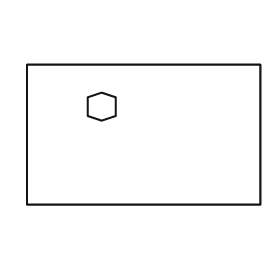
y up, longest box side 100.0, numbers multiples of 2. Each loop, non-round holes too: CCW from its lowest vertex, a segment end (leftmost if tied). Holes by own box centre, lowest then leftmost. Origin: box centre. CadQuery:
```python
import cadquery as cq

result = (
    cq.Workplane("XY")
    .moveTo(-50.0, -30.0)
    .lineTo(50.0, -30.0)
    .lineTo(50.0, 30.0)
    .lineTo(-50.0, 30.0)
    .close()
    .moveTo(-18.0, 6.0)
    .lineTo(-12.0, 8.0)
    .lineTo(-12.0, 16.0)
    .lineTo(-18.0, 18.0)
    .lineTo(-24.0, 16.0)
    .lineTo(-24.0, 8.0)
    .close()
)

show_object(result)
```